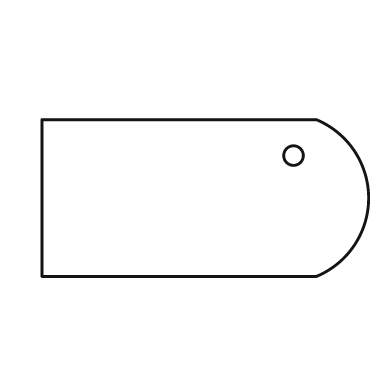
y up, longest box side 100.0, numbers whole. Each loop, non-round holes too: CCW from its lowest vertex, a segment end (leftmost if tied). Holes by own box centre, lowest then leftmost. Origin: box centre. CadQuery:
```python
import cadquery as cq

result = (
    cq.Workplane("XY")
    .moveTo(-50.0, -24.0)
    .lineTo(34.0, -24.0)
    .threePointArc((50.0, 0.0), (34.0, 24.0))
    .lineTo(-50.0, 24.0)
    .close()
    .moveTo(27.0, 13.0)
    .circle(3.0)
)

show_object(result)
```